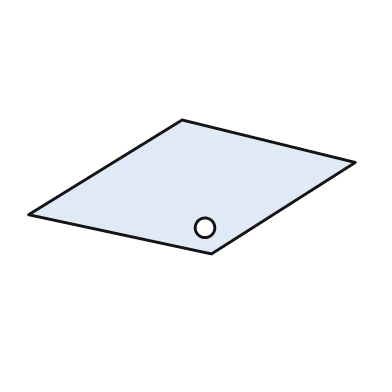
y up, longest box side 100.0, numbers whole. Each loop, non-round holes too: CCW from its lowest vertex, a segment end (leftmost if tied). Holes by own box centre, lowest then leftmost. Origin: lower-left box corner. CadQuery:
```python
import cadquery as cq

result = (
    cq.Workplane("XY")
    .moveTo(56.0, 0.0)
    .lineTo(100.0, 28.0)
    .lineTo(47.0, 41.0)
    .lineTo(0.0, 12.0)
    .close()
    .moveTo(54.0, 8.0)
    .circle(3.0)
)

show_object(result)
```